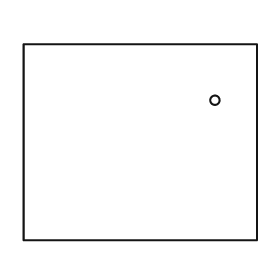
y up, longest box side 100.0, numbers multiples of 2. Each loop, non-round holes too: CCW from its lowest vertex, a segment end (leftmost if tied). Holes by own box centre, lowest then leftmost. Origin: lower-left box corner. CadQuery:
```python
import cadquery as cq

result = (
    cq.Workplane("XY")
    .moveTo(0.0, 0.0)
    .lineTo(100.0, 0.0)
    .lineTo(100.0, 84.0)
    .lineTo(0.0, 84.0)
    .close()
    .moveTo(82.0, 60.0)
    .circle(2.0)
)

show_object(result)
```